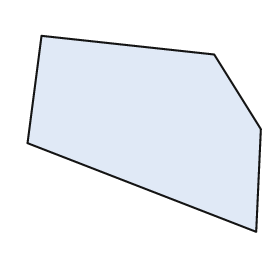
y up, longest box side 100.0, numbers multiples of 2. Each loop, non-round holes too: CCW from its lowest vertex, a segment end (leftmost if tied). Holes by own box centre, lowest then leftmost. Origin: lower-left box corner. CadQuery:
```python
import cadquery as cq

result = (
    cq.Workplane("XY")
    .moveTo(98.0, 0.0)
    .lineTo(100.0, 44.0)
    .lineTo(80.0, 76.0)
    .lineTo(6.0, 84.0)
    .lineTo(0.0, 38.0)
    .close()
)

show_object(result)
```